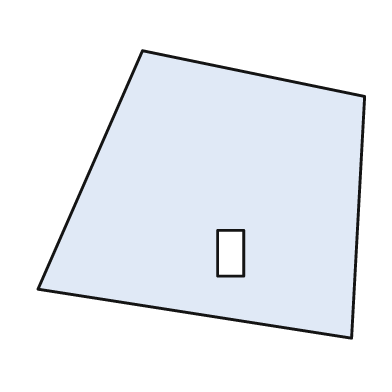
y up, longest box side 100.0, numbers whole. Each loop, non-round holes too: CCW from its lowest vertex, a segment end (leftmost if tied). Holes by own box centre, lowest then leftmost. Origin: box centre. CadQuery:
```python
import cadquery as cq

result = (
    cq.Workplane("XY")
    .moveTo(46.0, -44.0)
    .lineTo(50.0, 30.0)
    .lineTo(-18.0, 44.0)
    .lineTo(-50.0, -29.0)
    .close()
    .moveTo(5.0, -25.0)
    .lineTo(13.0, -25.0)
    .lineTo(13.0, -11.0)
    .lineTo(5.0, -11.0)
    .close()
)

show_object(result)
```